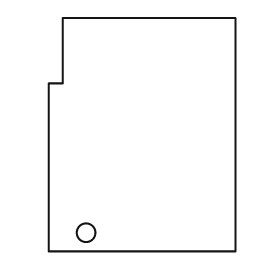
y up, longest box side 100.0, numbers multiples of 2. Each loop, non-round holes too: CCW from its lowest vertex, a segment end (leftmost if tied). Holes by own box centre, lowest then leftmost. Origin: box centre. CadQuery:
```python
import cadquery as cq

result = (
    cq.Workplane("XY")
    .moveTo(-40.0, -50.0)
    .lineTo(40.0, -50.0)
    .lineTo(40.0, 50.0)
    .lineTo(-34.0, 50.0)
    .lineTo(-34.0, 22.0)
    .lineTo(-40.0, 22.0)
    .close()
    .moveTo(-24.0, -42.0)
    .circle(4.0)
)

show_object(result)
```